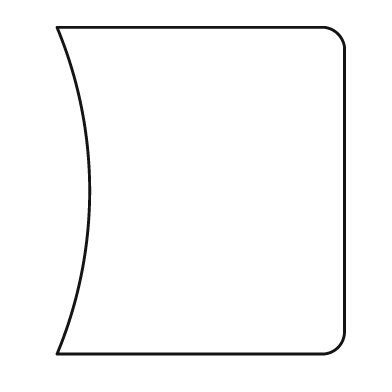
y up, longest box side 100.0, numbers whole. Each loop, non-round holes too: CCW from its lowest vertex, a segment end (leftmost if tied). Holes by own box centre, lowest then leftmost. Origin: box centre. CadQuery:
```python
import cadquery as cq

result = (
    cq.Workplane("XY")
    .moveTo(-44.0, -50.0)
    .lineTo(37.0, -50.0)
    .threePointArc((42.0, -48.0), (44.0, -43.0))
    .lineTo(44.0, 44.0)
    .threePointArc((42.0, 48.0), (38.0, 50.0))
    .lineTo(-44.0, 50.0)
    .threePointArc((-34.0, 0.0), (-44.0, -50.0))
    .close()
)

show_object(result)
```